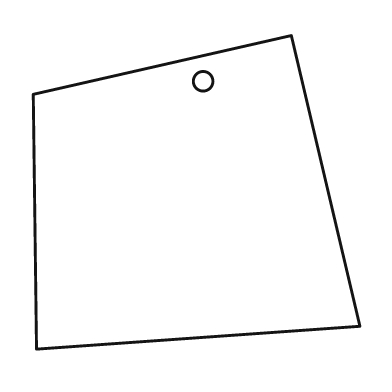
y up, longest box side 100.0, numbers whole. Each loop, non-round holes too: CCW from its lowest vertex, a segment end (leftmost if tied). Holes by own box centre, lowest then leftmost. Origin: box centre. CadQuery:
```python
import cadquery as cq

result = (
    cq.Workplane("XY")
    .moveTo(-49.0, -48.0)
    .lineTo(50.0, -41.0)
    .lineTo(29.0, 48.0)
    .lineTo(-50.0, 30.0)
    .close()
    .moveTo(2.0, 34.0)
    .circle(3.0)
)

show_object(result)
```